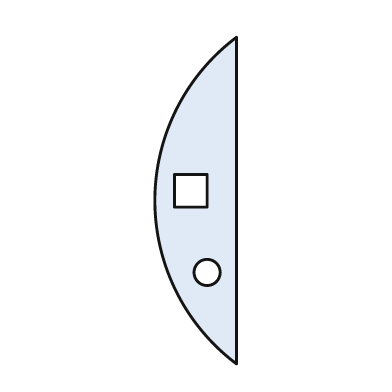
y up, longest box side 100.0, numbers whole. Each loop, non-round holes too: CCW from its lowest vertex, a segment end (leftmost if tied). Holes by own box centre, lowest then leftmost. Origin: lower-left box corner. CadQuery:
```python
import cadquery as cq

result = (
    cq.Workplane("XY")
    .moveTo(25.0, 0.0)
    .lineTo(25.0, 100.0)
    .threePointArc((0.0, 50.0), (25.0, 0.0))
    .close()
    .moveTo(16.0, 28.0)
    .circle(4.0)
    .moveTo(6.0, 48.0)
    .lineTo(16.0, 48.0)
    .lineTo(16.0, 58.0)
    .lineTo(6.0, 58.0)
    .close()
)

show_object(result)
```